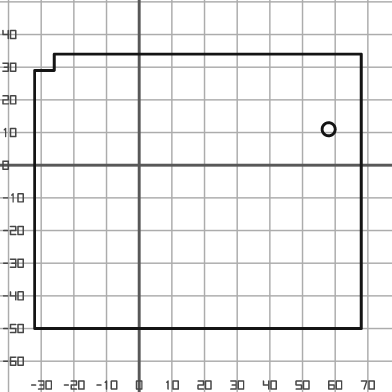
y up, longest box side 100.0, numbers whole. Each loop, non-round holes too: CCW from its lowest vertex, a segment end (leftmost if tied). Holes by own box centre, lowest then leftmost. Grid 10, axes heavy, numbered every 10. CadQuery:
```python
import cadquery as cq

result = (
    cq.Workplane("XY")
    .moveTo(-32.0, -50.0)
    .lineTo(68.0, -50.0)
    .lineTo(68.0, 34.0)
    .lineTo(-26.0, 34.0)
    .lineTo(-26.0, 29.0)
    .lineTo(-32.0, 29.0)
    .close()
    .moveTo(58.0, 11.0)
    .circle(2.0)
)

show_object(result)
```